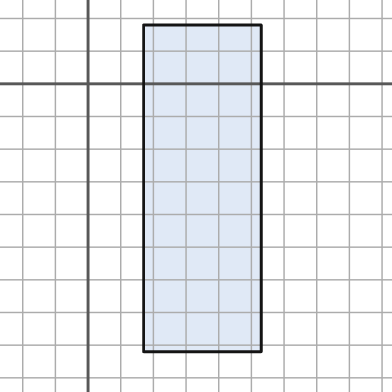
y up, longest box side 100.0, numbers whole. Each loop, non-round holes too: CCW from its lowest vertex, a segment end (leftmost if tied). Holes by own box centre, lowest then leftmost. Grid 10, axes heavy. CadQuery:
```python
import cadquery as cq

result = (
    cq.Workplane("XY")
    .moveTo(17.0, -82.0)
    .lineTo(53.0, -82.0)
    .lineTo(53.0, 18.0)
    .lineTo(17.0, 18.0)
    .close()
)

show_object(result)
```